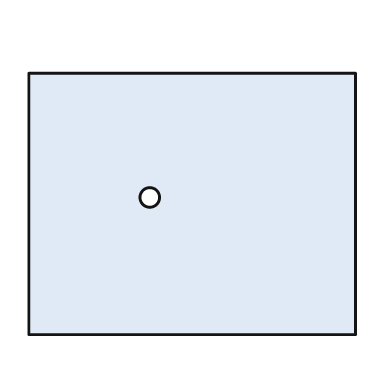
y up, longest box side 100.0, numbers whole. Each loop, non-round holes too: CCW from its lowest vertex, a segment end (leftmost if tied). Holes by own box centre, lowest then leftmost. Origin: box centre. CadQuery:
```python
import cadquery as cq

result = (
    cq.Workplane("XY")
    .moveTo(-50.0, -40.0)
    .lineTo(50.0, -40.0)
    .lineTo(50.0, 40.0)
    .lineTo(-50.0, 40.0)
    .close()
    .moveTo(-13.0, 2.0)
    .circle(3.0)
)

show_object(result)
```